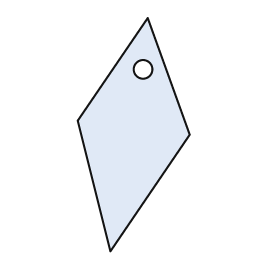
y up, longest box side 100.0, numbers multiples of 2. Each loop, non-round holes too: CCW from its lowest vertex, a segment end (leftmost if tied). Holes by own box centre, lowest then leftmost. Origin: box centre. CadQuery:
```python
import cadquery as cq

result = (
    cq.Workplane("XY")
    .moveTo(-10.0, -50.0)
    .lineTo(24.0, 0.0)
    .lineTo(6.0, 50.0)
    .lineTo(-24.0, 6.0)
    .close()
    .moveTo(4.0, 28.0)
    .circle(4.0)
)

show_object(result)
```